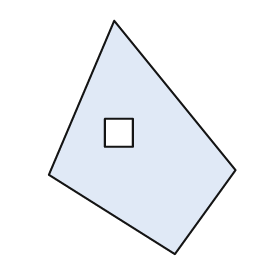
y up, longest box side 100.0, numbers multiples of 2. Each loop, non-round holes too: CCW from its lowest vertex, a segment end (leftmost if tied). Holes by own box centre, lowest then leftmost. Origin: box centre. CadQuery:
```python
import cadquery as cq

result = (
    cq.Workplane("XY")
    .moveTo(14.0, -50.0)
    .lineTo(40.0, -14.0)
    .lineTo(-12.0, 50.0)
    .lineTo(-40.0, -16.0)
    .close()
    .moveTo(-16.0, -4.0)
    .lineTo(-4.0, -4.0)
    .lineTo(-4.0, 8.0)
    .lineTo(-16.0, 8.0)
    .close()
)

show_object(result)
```